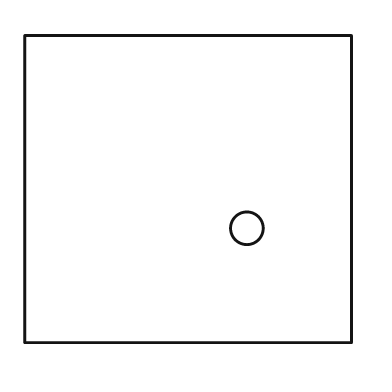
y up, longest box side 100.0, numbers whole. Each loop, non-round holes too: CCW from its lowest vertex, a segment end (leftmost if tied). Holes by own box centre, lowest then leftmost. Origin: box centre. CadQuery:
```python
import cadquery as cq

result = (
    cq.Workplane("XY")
    .moveTo(-50.0, -47.0)
    .lineTo(50.0, -47.0)
    .lineTo(50.0, 47.0)
    .lineTo(-50.0, 47.0)
    .close()
    .moveTo(18.0, -12.0)
    .circle(5.0)
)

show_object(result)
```